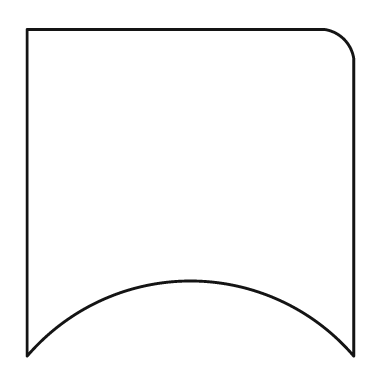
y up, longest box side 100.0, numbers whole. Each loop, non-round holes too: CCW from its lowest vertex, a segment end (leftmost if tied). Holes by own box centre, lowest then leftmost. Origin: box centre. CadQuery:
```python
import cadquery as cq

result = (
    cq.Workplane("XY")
    .moveTo(-50.0, -50.0)
    .threePointArc((0.0, -27.0), (50.0, -50.0))
    .lineTo(50.0, 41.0)
    .threePointArc((47.0, 47.0), (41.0, 50.0))
    .lineTo(-50.0, 50.0)
    .close()
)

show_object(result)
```